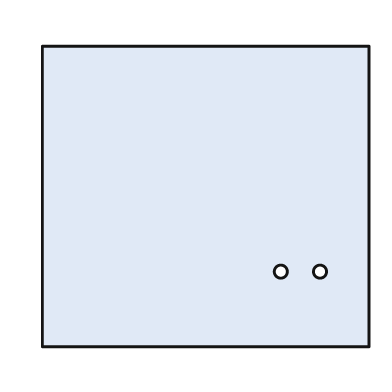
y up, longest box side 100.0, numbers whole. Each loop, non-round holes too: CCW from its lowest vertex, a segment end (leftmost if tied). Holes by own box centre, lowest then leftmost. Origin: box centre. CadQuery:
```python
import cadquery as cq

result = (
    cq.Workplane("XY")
    .moveTo(-50.0, -46.0)
    .lineTo(50.0, -46.0)
    .lineTo(50.0, 46.0)
    .lineTo(-50.0, 46.0)
    .close()
    .moveTo(23.0, -23.0)
    .circle(2.0)
    .moveTo(35.0, -23.0)
    .circle(2.0)
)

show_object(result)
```